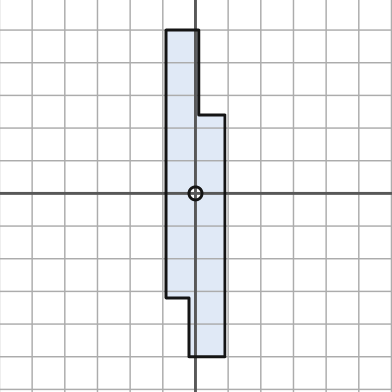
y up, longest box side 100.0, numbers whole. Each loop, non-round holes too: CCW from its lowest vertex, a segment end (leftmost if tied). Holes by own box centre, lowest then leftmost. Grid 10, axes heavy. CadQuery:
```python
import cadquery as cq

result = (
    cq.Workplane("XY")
    .moveTo(-2.0, -50.0)
    .lineTo(9.0, -50.0)
    .lineTo(9.0, 24.0)
    .lineTo(1.0, 24.0)
    .lineTo(1.0, 50.0)
    .lineTo(-9.0, 50.0)
    .lineTo(-9.0, -32.0)
    .lineTo(-2.0, -32.0)
    .close()
    .moveTo(0.0, 0.0)
    .circle(2.0)
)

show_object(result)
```